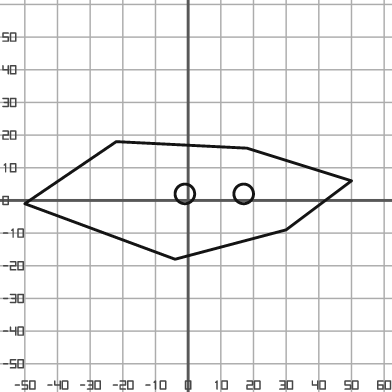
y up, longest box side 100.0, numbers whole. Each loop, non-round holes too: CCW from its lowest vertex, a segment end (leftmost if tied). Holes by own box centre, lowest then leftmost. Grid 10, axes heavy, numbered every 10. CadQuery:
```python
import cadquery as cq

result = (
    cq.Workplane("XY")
    .moveTo(-4.0, -18.0)
    .lineTo(30.0, -9.0)
    .lineTo(50.0, 6.0)
    .lineTo(18.0, 16.0)
    .lineTo(-22.0, 18.0)
    .lineTo(-50.0, -1.0)
    .close()
    .moveTo(-1.0, 2.0)
    .circle(3.0)
    .moveTo(17.0, 2.0)
    .circle(3.0)
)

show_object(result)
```